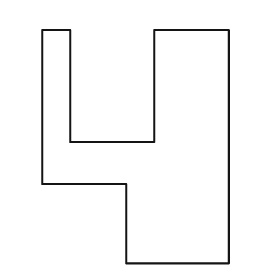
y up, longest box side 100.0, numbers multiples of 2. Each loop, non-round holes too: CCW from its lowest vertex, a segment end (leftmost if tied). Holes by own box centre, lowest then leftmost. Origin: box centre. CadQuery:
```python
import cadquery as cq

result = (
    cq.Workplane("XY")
    .moveTo(-4.0, -50.0)
    .lineTo(40.0, -50.0)
    .lineTo(40.0, 50.0)
    .lineTo(8.0, 50.0)
    .lineTo(8.0, 2.0)
    .lineTo(-28.0, 2.0)
    .lineTo(-28.0, 50.0)
    .lineTo(-40.0, 50.0)
    .lineTo(-40.0, -16.0)
    .lineTo(-4.0, -16.0)
    .close()
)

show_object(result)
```